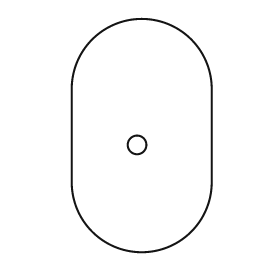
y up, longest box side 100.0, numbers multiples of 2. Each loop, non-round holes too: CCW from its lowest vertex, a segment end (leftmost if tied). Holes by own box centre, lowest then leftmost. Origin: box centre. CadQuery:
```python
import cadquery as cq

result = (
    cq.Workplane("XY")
    .moveTo(-30.0, -20.0)
    .threePointArc((0.0, -50.0), (30.0, -20.0))
    .lineTo(30.0, 20.0)
    .threePointArc((0.0, 50.0), (-30.0, 20.0))
    .close()
    .moveTo(-2.0, -4.0)
    .circle(4.0)
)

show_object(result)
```